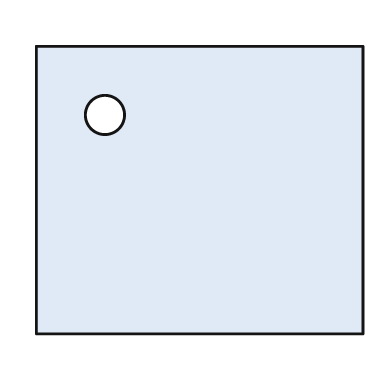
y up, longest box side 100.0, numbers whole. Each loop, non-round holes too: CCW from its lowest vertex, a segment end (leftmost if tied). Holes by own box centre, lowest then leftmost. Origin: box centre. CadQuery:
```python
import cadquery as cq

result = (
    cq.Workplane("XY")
    .moveTo(-50.0, -44.0)
    .lineTo(50.0, -44.0)
    .lineTo(50.0, 44.0)
    .lineTo(-50.0, 44.0)
    .close()
    .moveTo(-29.0, 23.0)
    .circle(6.0)
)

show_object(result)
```